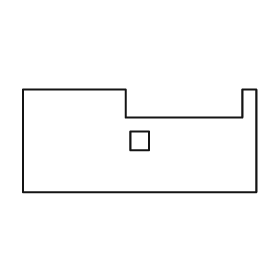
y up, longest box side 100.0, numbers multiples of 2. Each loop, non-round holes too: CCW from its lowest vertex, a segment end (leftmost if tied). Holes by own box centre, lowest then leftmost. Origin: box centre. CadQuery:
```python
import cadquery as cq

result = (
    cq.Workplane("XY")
    .moveTo(-50.0, -22.0)
    .lineTo(50.0, -22.0)
    .lineTo(50.0, 22.0)
    .lineTo(44.0, 22.0)
    .lineTo(44.0, 10.0)
    .lineTo(-6.0, 10.0)
    .lineTo(-6.0, 22.0)
    .lineTo(-50.0, 22.0)
    .close()
    .moveTo(-4.0, -4.0)
    .lineTo(4.0, -4.0)
    .lineTo(4.0, 4.0)
    .lineTo(-4.0, 4.0)
    .close()
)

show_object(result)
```